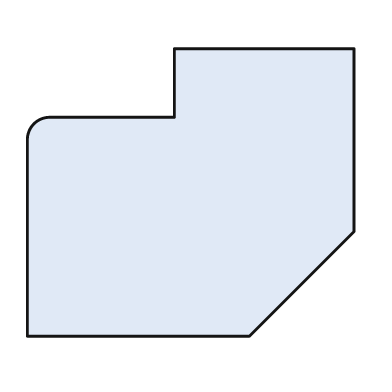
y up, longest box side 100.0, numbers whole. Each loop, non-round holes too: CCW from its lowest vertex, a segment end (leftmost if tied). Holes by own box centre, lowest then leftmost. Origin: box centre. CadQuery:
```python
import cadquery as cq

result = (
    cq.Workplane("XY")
    .moveTo(-50.0, -44.0)
    .lineTo(18.0, -44.0)
    .lineTo(50.0, -12.0)
    .lineTo(50.0, 44.0)
    .lineTo(-5.0, 44.0)
    .lineTo(-5.0, 23.0)
    .lineTo(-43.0, 23.0)
    .threePointArc((-48.0, 21.0), (-50.0, 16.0))
    .close()
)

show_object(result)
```